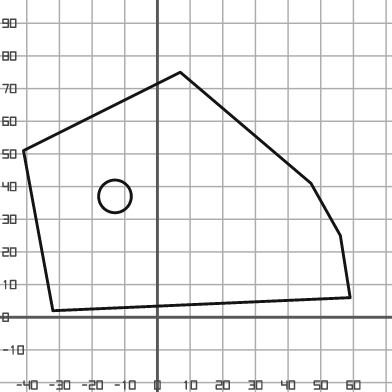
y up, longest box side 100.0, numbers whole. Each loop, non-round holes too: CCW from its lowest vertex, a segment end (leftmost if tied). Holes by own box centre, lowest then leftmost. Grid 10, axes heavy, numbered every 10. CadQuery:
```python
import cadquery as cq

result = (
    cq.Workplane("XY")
    .moveTo(-32.0, 2.0)
    .lineTo(59.0, 6.0)
    .lineTo(56.0, 25.0)
    .lineTo(47.0, 41.0)
    .lineTo(7.0, 75.0)
    .lineTo(-41.0, 51.0)
    .close()
    .moveTo(-13.0, 37.0)
    .circle(5.0)
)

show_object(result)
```